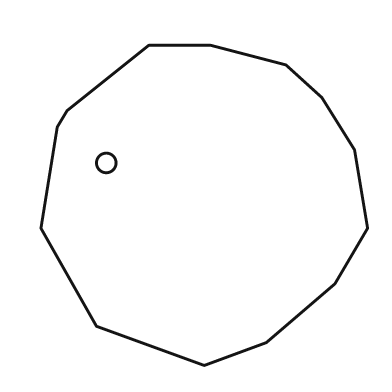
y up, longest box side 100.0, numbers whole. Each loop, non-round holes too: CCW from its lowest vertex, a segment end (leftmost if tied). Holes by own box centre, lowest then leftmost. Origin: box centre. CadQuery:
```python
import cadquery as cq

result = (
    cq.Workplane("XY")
    .moveTo(0.0, -49.0)
    .lineTo(19.0, -42.0)
    .lineTo(40.0, -24.0)
    .lineTo(50.0, -7.0)
    .lineTo(46.0, 17.0)
    .lineTo(36.0, 33.0)
    .lineTo(25.0, 43.0)
    .lineTo(2.0, 49.0)
    .lineTo(-17.0, 49.0)
    .lineTo(-42.0, 29.0)
    .lineTo(-45.0, 24.0)
    .lineTo(-50.0, -7.0)
    .lineTo(-33.0, -37.0)
    .close()
    .moveTo(-30.0, 13.0)
    .circle(3.0)
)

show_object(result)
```